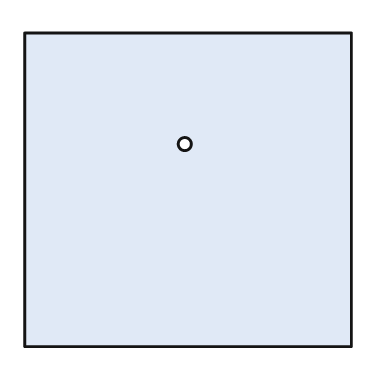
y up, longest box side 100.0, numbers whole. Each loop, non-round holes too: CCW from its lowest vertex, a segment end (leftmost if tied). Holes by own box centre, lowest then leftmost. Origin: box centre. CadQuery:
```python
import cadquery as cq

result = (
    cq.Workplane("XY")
    .moveTo(-50.0, -48.0)
    .lineTo(50.0, -48.0)
    .lineTo(50.0, 48.0)
    .lineTo(-50.0, 48.0)
    .close()
    .moveTo(-1.0, 14.0)
    .circle(2.0)
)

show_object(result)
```